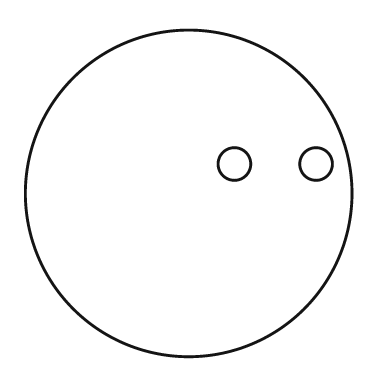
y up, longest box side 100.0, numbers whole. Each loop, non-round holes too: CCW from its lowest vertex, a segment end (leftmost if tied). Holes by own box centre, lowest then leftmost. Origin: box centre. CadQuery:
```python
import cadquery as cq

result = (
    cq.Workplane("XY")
    .moveTo(0.0, 0.0)
    .circle(50.0)
    .moveTo(14.0, 9.0)
    .circle(5.0)
    .moveTo(39.0, 9.0)
    .circle(5.0)
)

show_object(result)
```